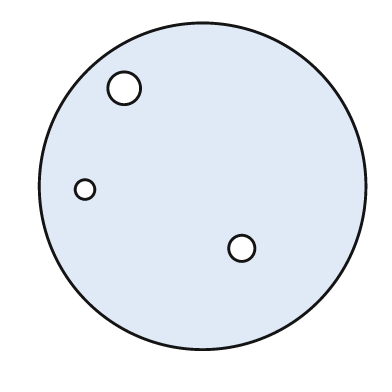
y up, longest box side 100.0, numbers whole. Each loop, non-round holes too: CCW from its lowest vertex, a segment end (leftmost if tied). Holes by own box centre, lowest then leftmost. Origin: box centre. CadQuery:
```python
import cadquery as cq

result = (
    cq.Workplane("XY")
    .moveTo(0.0, 0.0)
    .circle(50.0)
    .moveTo(12.0, -19.0)
    .circle(4.0)
    .moveTo(-36.0, -1.0)
    .circle(3.0)
    .moveTo(-24.0, 30.0)
    .circle(5.0)
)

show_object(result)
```